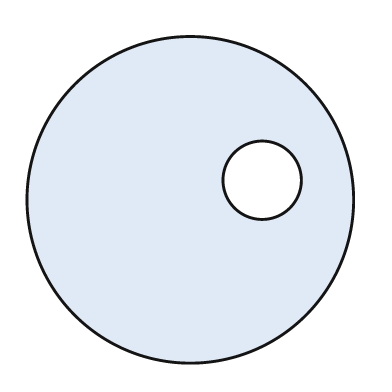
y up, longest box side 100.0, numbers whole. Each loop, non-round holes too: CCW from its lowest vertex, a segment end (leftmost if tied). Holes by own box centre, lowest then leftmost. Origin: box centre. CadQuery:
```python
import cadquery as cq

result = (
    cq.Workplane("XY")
    .moveTo(0.0, 0.0)
    .circle(50.0)
    .moveTo(22.0, 6.0)
    .circle(12.0)
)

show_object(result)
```